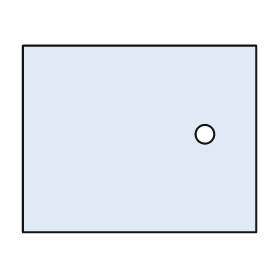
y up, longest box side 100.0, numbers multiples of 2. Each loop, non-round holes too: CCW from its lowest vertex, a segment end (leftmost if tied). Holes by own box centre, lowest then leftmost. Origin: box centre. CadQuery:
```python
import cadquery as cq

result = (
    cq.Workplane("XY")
    .moveTo(-50.0, -40.0)
    .lineTo(50.0, -40.0)
    .lineTo(50.0, 40.0)
    .lineTo(-50.0, 40.0)
    .close()
    .moveTo(28.0, 2.0)
    .circle(4.0)
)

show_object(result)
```